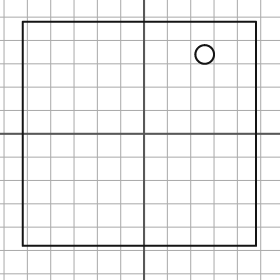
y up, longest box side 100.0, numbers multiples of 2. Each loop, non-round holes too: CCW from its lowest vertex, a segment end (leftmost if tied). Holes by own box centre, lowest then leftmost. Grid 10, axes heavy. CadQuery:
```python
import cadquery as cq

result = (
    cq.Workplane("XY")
    .moveTo(-52.0, -48.0)
    .lineTo(48.0, -48.0)
    .lineTo(48.0, 48.0)
    .lineTo(-52.0, 48.0)
    .close()
    .moveTo(26.0, 34.0)
    .circle(4.0)
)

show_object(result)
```